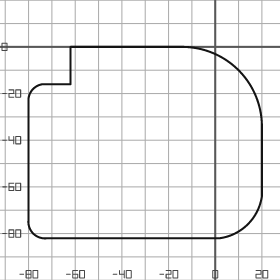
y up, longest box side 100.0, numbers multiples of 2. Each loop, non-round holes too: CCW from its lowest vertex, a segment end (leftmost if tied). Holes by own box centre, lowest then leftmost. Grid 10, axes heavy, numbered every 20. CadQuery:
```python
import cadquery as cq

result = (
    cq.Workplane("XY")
    .moveTo(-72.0, -82.0)
    .lineTo(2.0, -82.0)
    .threePointArc((14.0, -76.0), (20.0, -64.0))
    .lineTo(20.0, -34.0)
    .threePointArc((10.0, -10.0), (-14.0, 0.0))
    .lineTo(-62.0, 0.0)
    .lineTo(-62.0, -16.0)
    .lineTo(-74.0, -16.0)
    .threePointArc((-78.0, -18.0), (-80.0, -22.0))
    .lineTo(-80.0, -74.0)
    .threePointArc((-78.0, -80.0), (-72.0, -82.0))
    .close()
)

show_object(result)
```